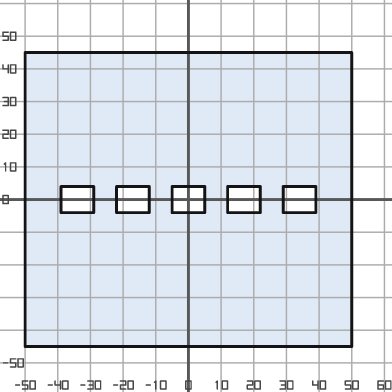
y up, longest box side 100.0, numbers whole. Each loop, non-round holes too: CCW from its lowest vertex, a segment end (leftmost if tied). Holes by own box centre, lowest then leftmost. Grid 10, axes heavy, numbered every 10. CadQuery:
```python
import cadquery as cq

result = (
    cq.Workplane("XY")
    .moveTo(-50.0, -45.0)
    .lineTo(50.0, -45.0)
    .lineTo(50.0, 45.0)
    .lineTo(-50.0, 45.0)
    .close()
    .moveTo(-39.0, -4.0)
    .lineTo(-29.0, -4.0)
    .lineTo(-29.0, 4.0)
    .lineTo(-39.0, 4.0)
    .close()
    .moveTo(-22.0, -4.0)
    .lineTo(-12.0, -4.0)
    .lineTo(-12.0, 4.0)
    .lineTo(-22.0, 4.0)
    .close()
    .moveTo(-5.0, -4.0)
    .lineTo(5.0, -4.0)
    .lineTo(5.0, 4.0)
    .lineTo(-5.0, 4.0)
    .close()
    .moveTo(12.0, -4.0)
    .lineTo(22.0, -4.0)
    .lineTo(22.0, 4.0)
    .lineTo(12.0, 4.0)
    .close()
    .moveTo(29.0, -4.0)
    .lineTo(39.0, -4.0)
    .lineTo(39.0, 4.0)
    .lineTo(29.0, 4.0)
    .close()
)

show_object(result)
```